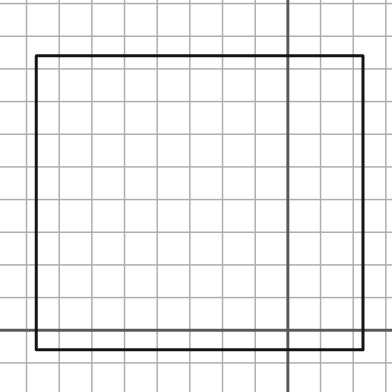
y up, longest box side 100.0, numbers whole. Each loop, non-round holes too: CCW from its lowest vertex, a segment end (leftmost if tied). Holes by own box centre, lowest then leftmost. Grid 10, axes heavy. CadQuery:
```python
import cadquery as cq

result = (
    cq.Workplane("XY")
    .moveTo(-77.0, -6.0)
    .lineTo(23.0, -6.0)
    .lineTo(23.0, 84.0)
    .lineTo(-77.0, 84.0)
    .close()
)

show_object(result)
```